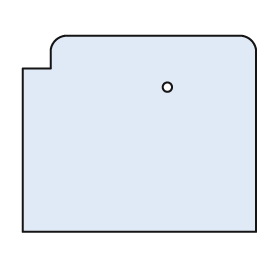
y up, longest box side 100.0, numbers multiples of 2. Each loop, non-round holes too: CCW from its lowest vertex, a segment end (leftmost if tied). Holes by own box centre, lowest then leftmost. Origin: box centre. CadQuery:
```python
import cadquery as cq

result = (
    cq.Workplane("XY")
    .moveTo(-50.0, -42.0)
    .lineTo(50.0, -42.0)
    .lineTo(50.0, 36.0)
    .threePointArc((48.0, 40.0), (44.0, 42.0))
    .lineTo(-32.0, 42.0)
    .threePointArc((-36.0, 40.0), (-38.0, 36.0))
    .lineTo(-38.0, 28.0)
    .lineTo(-50.0, 28.0)
    .close()
    .moveTo(12.0, 20.0)
    .circle(2.0)
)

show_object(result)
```